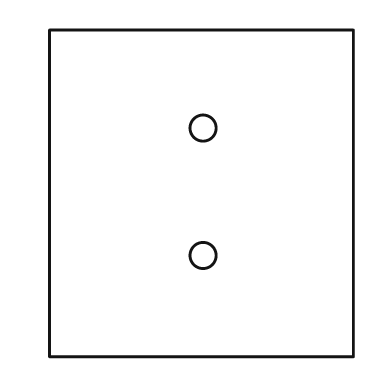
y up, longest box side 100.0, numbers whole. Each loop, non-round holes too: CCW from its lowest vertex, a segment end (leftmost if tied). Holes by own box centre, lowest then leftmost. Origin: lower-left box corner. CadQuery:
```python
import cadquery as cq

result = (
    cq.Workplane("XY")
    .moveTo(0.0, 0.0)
    .lineTo(93.0, 0.0)
    .lineTo(93.0, 100.0)
    .lineTo(0.0, 100.0)
    .close()
    .moveTo(47.0, 31.0)
    .circle(4.0)
    .moveTo(47.0, 70.0)
    .circle(4.0)
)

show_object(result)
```